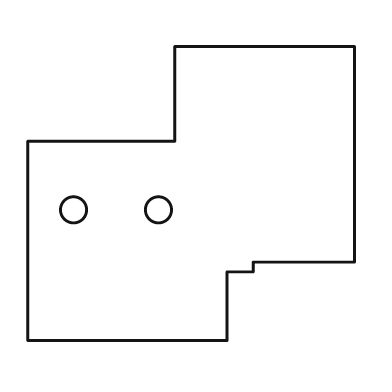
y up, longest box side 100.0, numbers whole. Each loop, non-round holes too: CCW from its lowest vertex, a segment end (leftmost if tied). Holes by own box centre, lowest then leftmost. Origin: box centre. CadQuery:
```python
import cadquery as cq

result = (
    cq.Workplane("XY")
    .moveTo(-50.0, -45.0)
    .lineTo(11.0, -45.0)
    .lineTo(11.0, -24.0)
    .lineTo(19.0, -24.0)
    .lineTo(19.0, -21.0)
    .lineTo(50.0, -21.0)
    .lineTo(50.0, 45.0)
    .lineTo(-5.0, 45.0)
    .lineTo(-5.0, 16.0)
    .lineTo(-50.0, 16.0)
    .close()
    .moveTo(-36.0, -5.0)
    .circle(4.0)
    .moveTo(-10.0, -5.0)
    .circle(4.0)
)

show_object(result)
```